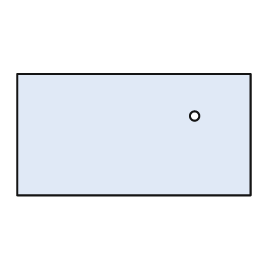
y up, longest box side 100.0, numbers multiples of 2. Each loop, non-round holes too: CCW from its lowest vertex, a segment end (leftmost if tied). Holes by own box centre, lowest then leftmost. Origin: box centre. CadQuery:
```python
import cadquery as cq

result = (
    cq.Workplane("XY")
    .moveTo(-50.0, -26.0)
    .lineTo(50.0, -26.0)
    .lineTo(50.0, 26.0)
    .lineTo(-50.0, 26.0)
    .close()
    .moveTo(26.0, 8.0)
    .circle(2.0)
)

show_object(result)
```